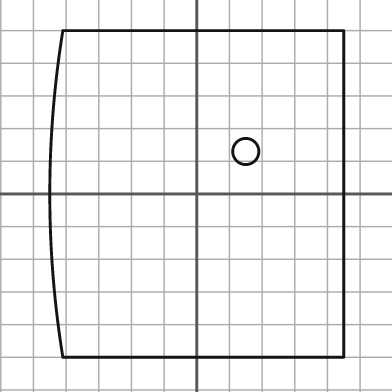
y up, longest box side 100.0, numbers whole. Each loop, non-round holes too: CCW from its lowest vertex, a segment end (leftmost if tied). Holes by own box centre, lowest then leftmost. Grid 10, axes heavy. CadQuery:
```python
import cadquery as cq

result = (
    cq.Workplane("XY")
    .moveTo(-41.0, -50.0)
    .lineTo(45.0, -50.0)
    .lineTo(45.0, 50.0)
    .lineTo(-41.0, 50.0)
    .threePointArc((-45.0, 0.0), (-41.0, -50.0))
    .close()
    .moveTo(15.0, 13.0)
    .circle(4.0)
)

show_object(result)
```